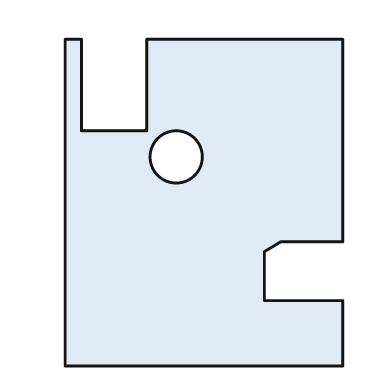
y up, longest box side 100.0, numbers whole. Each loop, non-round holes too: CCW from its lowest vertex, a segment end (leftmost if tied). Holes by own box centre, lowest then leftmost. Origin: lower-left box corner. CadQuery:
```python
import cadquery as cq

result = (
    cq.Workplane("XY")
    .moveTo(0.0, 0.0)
    .lineTo(85.0, 0.0)
    .lineTo(85.0, 20.0)
    .lineTo(61.0, 20.0)
    .lineTo(61.0, 35.0)
    .lineTo(66.0, 38.0)
    .lineTo(85.0, 38.0)
    .lineTo(85.0, 100.0)
    .lineTo(25.0, 100.0)
    .lineTo(25.0, 72.0)
    .lineTo(5.0, 72.0)
    .lineTo(5.0, 100.0)
    .lineTo(0.0, 100.0)
    .close()
    .moveTo(34.0, 64.0)
    .circle(8.0)
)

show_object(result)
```